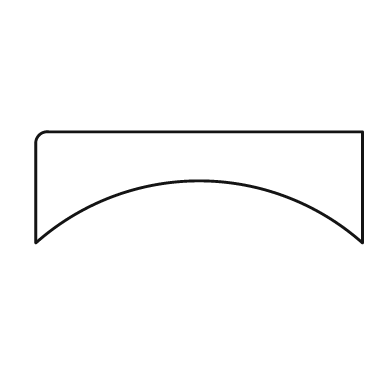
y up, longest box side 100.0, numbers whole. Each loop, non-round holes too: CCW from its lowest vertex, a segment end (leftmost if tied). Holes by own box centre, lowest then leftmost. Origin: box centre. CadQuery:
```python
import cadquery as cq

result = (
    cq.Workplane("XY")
    .moveTo(-50.0, -17.0)
    .threePointArc((0.0, 2.0), (50.0, -17.0))
    .lineTo(50.0, 17.0)
    .lineTo(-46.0, 17.0)
    .threePointArc((-49.0, 16.0), (-50.0, 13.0))
    .close()
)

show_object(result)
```